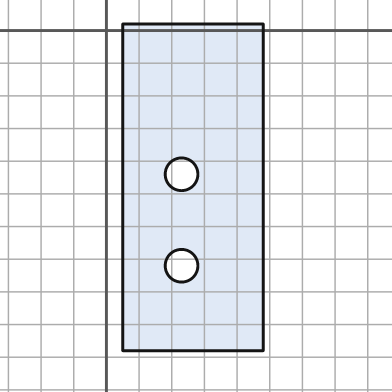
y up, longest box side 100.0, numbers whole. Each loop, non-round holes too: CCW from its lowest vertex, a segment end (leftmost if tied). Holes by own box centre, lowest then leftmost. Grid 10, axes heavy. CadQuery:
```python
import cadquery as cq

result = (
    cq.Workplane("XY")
    .moveTo(5.0, -98.0)
    .lineTo(48.0, -98.0)
    .lineTo(48.0, 2.0)
    .lineTo(5.0, 2.0)
    .close()
    .moveTo(23.0, -72.0)
    .circle(5.0)
    .moveTo(23.0, -44.0)
    .circle(5.0)
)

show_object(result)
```